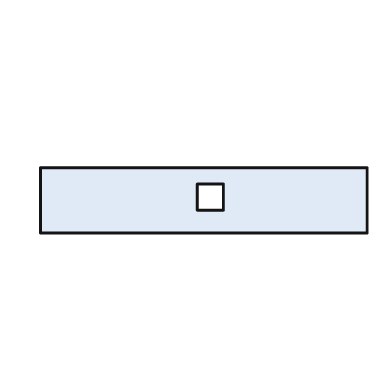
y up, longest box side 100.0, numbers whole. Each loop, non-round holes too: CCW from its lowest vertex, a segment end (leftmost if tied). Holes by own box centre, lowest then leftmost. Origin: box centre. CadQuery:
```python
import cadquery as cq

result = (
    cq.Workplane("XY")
    .moveTo(-50.0, -10.0)
    .lineTo(50.0, -10.0)
    .lineTo(50.0, 10.0)
    .lineTo(-50.0, 10.0)
    .close()
    .moveTo(-2.0, -3.0)
    .lineTo(6.0, -3.0)
    .lineTo(6.0, 5.0)
    .lineTo(-2.0, 5.0)
    .close()
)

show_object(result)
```